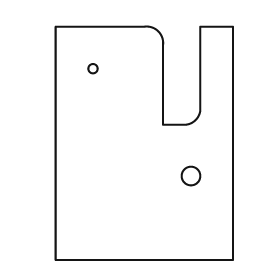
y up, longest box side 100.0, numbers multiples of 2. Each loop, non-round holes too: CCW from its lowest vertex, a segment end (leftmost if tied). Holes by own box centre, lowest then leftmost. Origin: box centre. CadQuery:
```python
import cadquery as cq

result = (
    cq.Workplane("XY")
    .moveTo(-38.0, -50.0)
    .lineTo(38.0, -50.0)
    .lineTo(38.0, 50.0)
    .lineTo(24.0, 50.0)
    .lineTo(24.0, 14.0)
    .threePointArc((22.0, 10.0), (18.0, 8.0))
    .lineTo(8.0, 8.0)
    .lineTo(8.0, 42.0)
    .threePointArc((6.0, 48.0), (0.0, 50.0))
    .lineTo(-38.0, 50.0)
    .close()
    .moveTo(20.0, -14.0)
    .circle(4.0)
    .moveTo(-22.0, 32.0)
    .circle(2.0)
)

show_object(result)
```